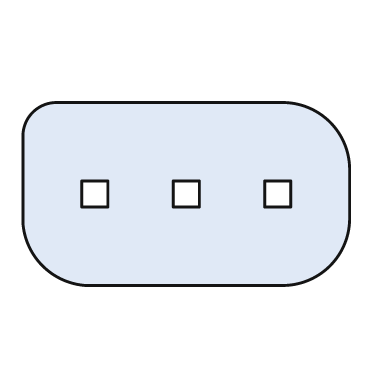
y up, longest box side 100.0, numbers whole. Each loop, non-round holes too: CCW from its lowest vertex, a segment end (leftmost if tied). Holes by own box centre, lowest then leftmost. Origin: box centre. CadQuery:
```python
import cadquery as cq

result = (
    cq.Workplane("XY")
    .moveTo(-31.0, -28.0)
    .lineTo(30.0, -28.0)
    .threePointArc((44.0, -22.0), (50.0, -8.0))
    .lineTo(50.0, 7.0)
    .threePointArc((44.0, 22.0), (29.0, 28.0))
    .lineTo(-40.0, 28.0)
    .threePointArc((-47.0, 25.0), (-50.0, 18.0))
    .lineTo(-50.0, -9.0)
    .threePointArc((-44.0, -22.0), (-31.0, -28.0))
    .close()
    .moveTo(-32.0, -4.0)
    .lineTo(-24.0, -4.0)
    .lineTo(-24.0, 4.0)
    .lineTo(-32.0, 4.0)
    .close()
    .moveTo(-4.0, -4.0)
    .lineTo(4.0, -4.0)
    .lineTo(4.0, 4.0)
    .lineTo(-4.0, 4.0)
    .close()
    .moveTo(24.0, -4.0)
    .lineTo(32.0, -4.0)
    .lineTo(32.0, 4.0)
    .lineTo(24.0, 4.0)
    .close()
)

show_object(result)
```